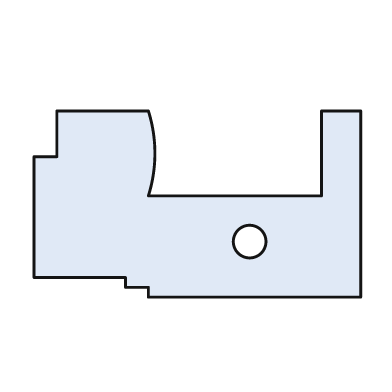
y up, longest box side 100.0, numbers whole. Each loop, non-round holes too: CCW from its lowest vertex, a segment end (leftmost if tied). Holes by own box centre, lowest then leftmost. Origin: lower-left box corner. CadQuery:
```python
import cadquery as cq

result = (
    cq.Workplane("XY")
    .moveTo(35.0, 0.0)
    .lineTo(100.0, 0.0)
    .lineTo(100.0, 57.0)
    .lineTo(88.0, 57.0)
    .lineTo(88.0, 31.0)
    .lineTo(35.0, 31.0)
    .threePointArc((37.0, 44.0), (35.0, 57.0))
    .lineTo(7.0, 57.0)
    .lineTo(7.0, 43.0)
    .lineTo(0.0, 43.0)
    .lineTo(0.0, 6.0)
    .lineTo(28.0, 6.0)
    .lineTo(28.0, 3.0)
    .lineTo(35.0, 3.0)
    .close()
    .moveTo(66.0, 17.0)
    .circle(5.0)
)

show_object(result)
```